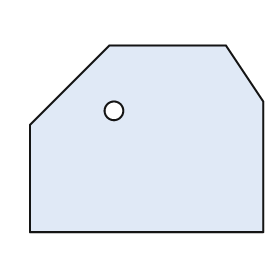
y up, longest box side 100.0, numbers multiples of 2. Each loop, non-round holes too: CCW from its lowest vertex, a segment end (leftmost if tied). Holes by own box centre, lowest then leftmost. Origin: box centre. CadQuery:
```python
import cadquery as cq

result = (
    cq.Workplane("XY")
    .moveTo(-50.0, -40.0)
    .lineTo(50.0, -40.0)
    .lineTo(50.0, 16.0)
    .lineTo(34.0, 40.0)
    .lineTo(-16.0, 40.0)
    .lineTo(-50.0, 6.0)
    .close()
    .moveTo(-14.0, 12.0)
    .circle(4.0)
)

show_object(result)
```